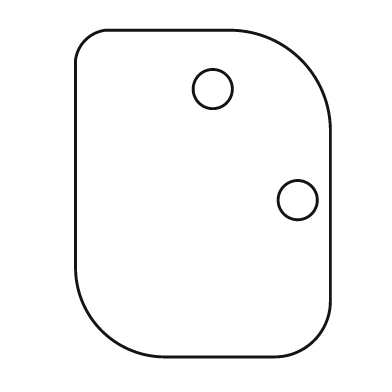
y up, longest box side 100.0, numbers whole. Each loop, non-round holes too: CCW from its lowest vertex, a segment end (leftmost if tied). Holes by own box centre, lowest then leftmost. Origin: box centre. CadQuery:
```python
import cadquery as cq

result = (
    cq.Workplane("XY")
    .moveTo(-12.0, -50.0)
    .lineTo(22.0, -50.0)
    .threePointArc((34.0, -45.0), (39.0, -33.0))
    .lineTo(39.0, 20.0)
    .threePointArc((30.0, 41.0), (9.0, 50.0))
    .lineTo(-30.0, 50.0)
    .threePointArc((-36.0, 47.0), (-39.0, 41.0))
    .lineTo(-39.0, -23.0)
    .threePointArc((-31.0, -42.0), (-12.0, -50.0))
    .close()
    .moveTo(29.0, -2.0)
    .circle(6.0)
    .moveTo(3.0, 32.0)
    .circle(6.0)
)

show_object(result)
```